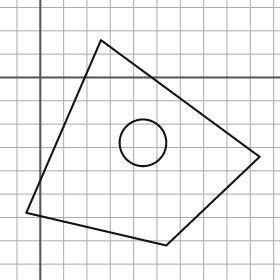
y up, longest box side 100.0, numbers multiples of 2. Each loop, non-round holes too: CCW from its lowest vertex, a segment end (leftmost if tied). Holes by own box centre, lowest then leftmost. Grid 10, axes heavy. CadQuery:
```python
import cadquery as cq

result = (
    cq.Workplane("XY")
    .moveTo(54.0, -72.0)
    .lineTo(94.0, -34.0)
    .lineTo(26.0, 16.0)
    .lineTo(-6.0, -58.0)
    .close()
    .moveTo(44.0, -28.0)
    .circle(10.0)
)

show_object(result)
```